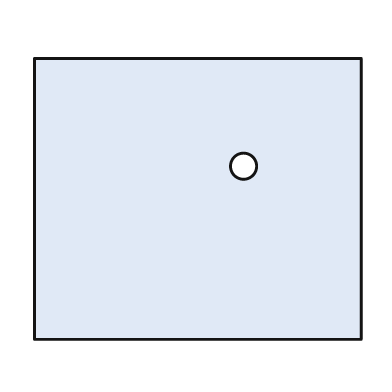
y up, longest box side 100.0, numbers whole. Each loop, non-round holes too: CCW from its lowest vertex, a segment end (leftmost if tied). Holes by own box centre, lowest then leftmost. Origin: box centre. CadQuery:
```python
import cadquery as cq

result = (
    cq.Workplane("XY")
    .moveTo(-50.0, -43.0)
    .lineTo(50.0, -43.0)
    .lineTo(50.0, 43.0)
    .lineTo(-50.0, 43.0)
    .close()
    .moveTo(14.0, 10.0)
    .circle(4.0)
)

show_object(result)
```